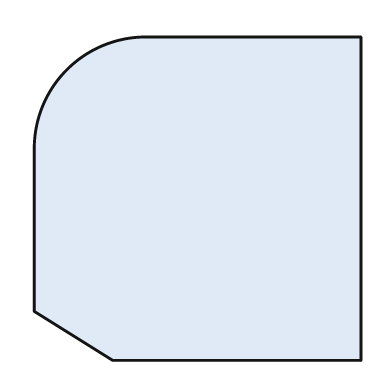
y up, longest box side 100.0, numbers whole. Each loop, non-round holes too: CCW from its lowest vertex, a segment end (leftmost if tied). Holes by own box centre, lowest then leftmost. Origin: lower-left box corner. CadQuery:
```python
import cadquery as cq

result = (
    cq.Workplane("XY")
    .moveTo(24.0, 0.0)
    .lineTo(100.0, 0.0)
    .lineTo(100.0, 99.0)
    .lineTo(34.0, 99.0)
    .threePointArc((10.0, 89.0), (0.0, 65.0))
    .lineTo(0.0, 15.0)
    .close()
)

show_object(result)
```